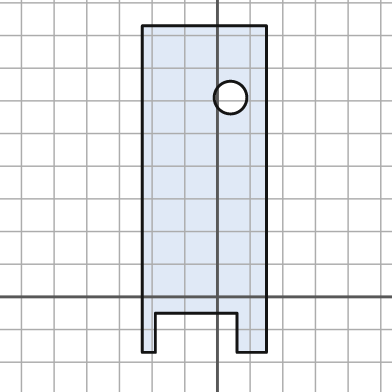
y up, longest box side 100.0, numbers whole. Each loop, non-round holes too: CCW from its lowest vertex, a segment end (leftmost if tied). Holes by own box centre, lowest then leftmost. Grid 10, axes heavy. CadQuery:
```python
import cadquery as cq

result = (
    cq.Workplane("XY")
    .moveTo(-23.0, -17.0)
    .lineTo(-19.0, -17.0)
    .lineTo(-19.0, -5.0)
    .lineTo(6.0, -5.0)
    .lineTo(6.0, -17.0)
    .lineTo(15.0, -17.0)
    .lineTo(15.0, 83.0)
    .lineTo(-23.0, 83.0)
    .close()
    .moveTo(4.0, 61.0)
    .circle(5.0)
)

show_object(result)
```